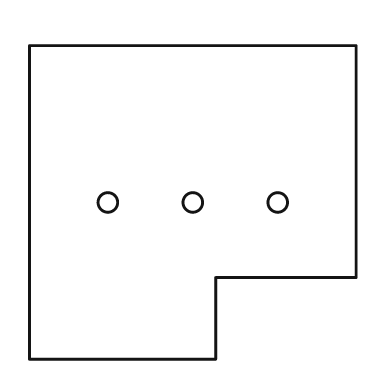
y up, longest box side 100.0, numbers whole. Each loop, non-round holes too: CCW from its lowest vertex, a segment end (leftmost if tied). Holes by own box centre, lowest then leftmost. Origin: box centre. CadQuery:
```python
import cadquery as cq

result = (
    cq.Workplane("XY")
    .moveTo(-50.0, -48.0)
    .lineTo(7.0, -48.0)
    .lineTo(7.0, -23.0)
    .lineTo(50.0, -23.0)
    .lineTo(50.0, 48.0)
    .lineTo(-50.0, 48.0)
    .close()
    .moveTo(-26.0, 0.0)
    .circle(3.0)
    .moveTo(0.0, 0.0)
    .circle(3.0)
    .moveTo(26.0, 0.0)
    .circle(3.0)
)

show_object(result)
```